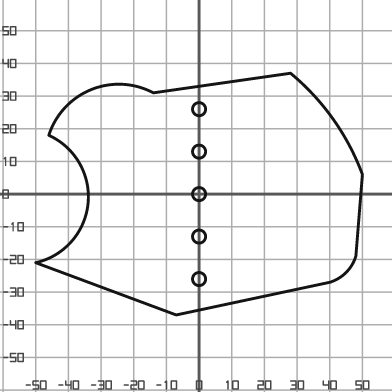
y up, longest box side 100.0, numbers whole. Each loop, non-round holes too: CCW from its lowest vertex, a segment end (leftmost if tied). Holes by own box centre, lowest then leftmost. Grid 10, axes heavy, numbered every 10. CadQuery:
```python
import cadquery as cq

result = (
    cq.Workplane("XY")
    .moveTo(-7.0, -37.0)
    .lineTo(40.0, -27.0)
    .threePointArc((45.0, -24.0), (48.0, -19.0))
    .lineTo(50.0, 6.0)
    .threePointArc((41.0, 23.0), (28.0, 37.0))
    .lineTo(-14.0, 31.0)
    .threePointArc((-33.0, 32.0), (-46.0, 18.0))
    .threePointArc((-34.0, -3.0), (-50.0, -21.0))
    .close()
    .moveTo(0.0, -26.0)
    .circle(2.0)
    .moveTo(0.0, -13.0)
    .circle(2.0)
    .moveTo(0.0, 0.0)
    .circle(2.0)
    .moveTo(0.0, 13.0)
    .circle(2.0)
    .moveTo(0.0, 26.0)
    .circle(2.0)
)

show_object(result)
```